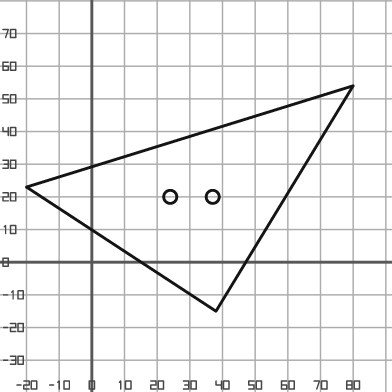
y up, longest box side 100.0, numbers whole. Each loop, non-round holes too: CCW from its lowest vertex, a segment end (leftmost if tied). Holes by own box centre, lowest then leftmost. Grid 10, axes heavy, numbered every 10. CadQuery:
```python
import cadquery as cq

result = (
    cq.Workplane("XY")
    .moveTo(38.0, -15.0)
    .lineTo(80.0, 54.0)
    .lineTo(-20.0, 23.0)
    .close()
    .moveTo(24.0, 20.0)
    .circle(2.0)
    .moveTo(37.0, 20.0)
    .circle(2.0)
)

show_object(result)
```